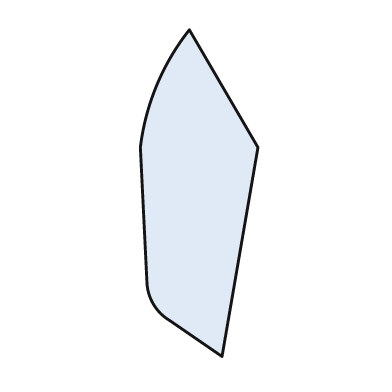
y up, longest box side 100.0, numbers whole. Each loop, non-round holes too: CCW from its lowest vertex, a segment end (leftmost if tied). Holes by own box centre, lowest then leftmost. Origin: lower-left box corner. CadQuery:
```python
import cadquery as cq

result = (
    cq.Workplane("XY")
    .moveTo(25.0, 0.0)
    .lineTo(36.0, 64.0)
    .lineTo(15.0, 100.0)
    .threePointArc((5.0, 83.0), (0.0, 64.0))
    .lineTo(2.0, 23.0)
    .threePointArc((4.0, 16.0), (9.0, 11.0))
    .close()
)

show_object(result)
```